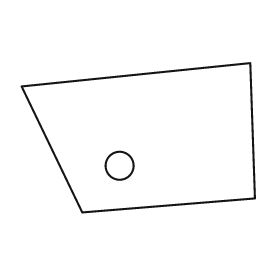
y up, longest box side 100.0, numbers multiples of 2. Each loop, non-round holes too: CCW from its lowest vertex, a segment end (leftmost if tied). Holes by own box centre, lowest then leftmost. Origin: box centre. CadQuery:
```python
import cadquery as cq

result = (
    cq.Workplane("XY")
    .moveTo(-24.0, -32.0)
    .lineTo(50.0, -26.0)
    .lineTo(48.0, 32.0)
    .lineTo(-50.0, 22.0)
    .close()
    .moveTo(-8.0, -12.0)
    .circle(6.0)
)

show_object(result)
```